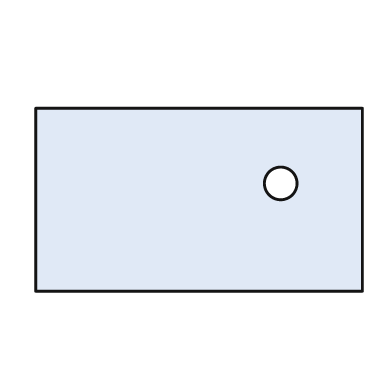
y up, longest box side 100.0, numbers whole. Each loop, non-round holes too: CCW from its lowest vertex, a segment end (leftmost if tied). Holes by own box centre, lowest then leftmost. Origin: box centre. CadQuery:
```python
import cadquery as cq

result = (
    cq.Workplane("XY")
    .moveTo(-50.0, -28.0)
    .lineTo(50.0, -28.0)
    .lineTo(50.0, 28.0)
    .lineTo(-50.0, 28.0)
    .close()
    .moveTo(25.0, 5.0)
    .circle(5.0)
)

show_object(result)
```